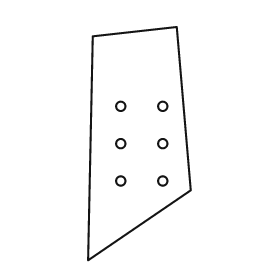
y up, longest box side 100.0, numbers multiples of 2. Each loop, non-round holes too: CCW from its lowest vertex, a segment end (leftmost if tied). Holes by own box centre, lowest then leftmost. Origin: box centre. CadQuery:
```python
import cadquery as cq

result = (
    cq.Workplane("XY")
    .moveTo(-22.0, -50.0)
    .lineTo(22.0, -20.0)
    .lineTo(16.0, 50.0)
    .lineTo(-20.0, 46.0)
    .close()
    .moveTo(-8.0, -16.0)
    .circle(2.0)
    .moveTo(10.0, -16.0)
    .circle(2.0)
    .moveTo(-8.0, 0.0)
    .circle(2.0)
    .moveTo(10.0, 0.0)
    .circle(2.0)
    .moveTo(-8.0, 16.0)
    .circle(2.0)
    .moveTo(10.0, 16.0)
    .circle(2.0)
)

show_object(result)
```